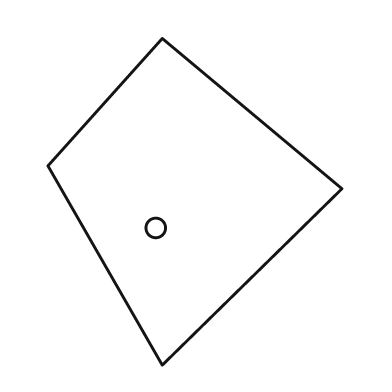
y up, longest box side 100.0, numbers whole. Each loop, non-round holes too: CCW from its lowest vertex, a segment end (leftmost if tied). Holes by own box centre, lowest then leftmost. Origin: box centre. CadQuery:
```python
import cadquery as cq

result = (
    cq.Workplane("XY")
    .moveTo(-10.0, -50.0)
    .lineTo(45.0, 4.0)
    .lineTo(-10.0, 50.0)
    .lineTo(-45.0, 11.0)
    .close()
    .moveTo(-12.0, -8.0)
    .circle(3.0)
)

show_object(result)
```